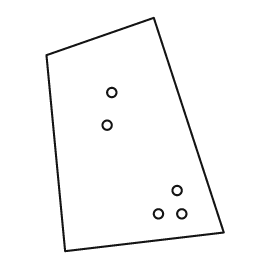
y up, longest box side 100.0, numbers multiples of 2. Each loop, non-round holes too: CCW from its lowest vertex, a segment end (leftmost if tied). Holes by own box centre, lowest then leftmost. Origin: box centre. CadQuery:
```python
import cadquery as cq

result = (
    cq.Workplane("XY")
    .moveTo(-30.0, -50.0)
    .lineTo(38.0, -42.0)
    .lineTo(8.0, 50.0)
    .lineTo(-38.0, 34.0)
    .close()
    .moveTo(10.0, -34.0)
    .circle(2.0)
    .moveTo(20.0, -34.0)
    .circle(2.0)
    .moveTo(18.0, -24.0)
    .circle(2.0)
    .moveTo(-12.0, 4.0)
    .circle(2.0)
    .moveTo(-10.0, 18.0)
    .circle(2.0)
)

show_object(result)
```